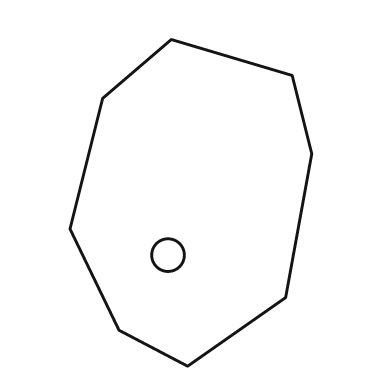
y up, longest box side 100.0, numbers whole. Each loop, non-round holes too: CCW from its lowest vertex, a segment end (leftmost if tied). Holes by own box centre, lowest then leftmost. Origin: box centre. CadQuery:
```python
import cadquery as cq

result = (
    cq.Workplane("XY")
    .moveTo(-1.0, -50.0)
    .lineTo(29.0, -29.0)
    .lineTo(37.0, 15.0)
    .lineTo(31.0, 39.0)
    .lineTo(-6.0, 50.0)
    .lineTo(-27.0, 32.0)
    .lineTo(-37.0, -8.0)
    .lineTo(-22.0, -39.0)
    .close()
    .moveTo(-7.0, -16.0)
    .circle(5.0)
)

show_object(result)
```